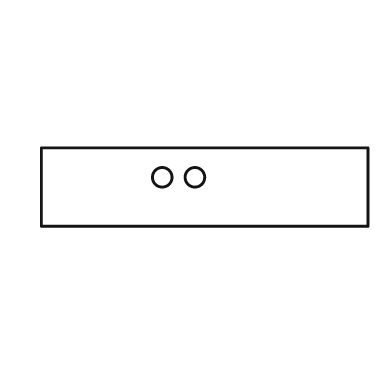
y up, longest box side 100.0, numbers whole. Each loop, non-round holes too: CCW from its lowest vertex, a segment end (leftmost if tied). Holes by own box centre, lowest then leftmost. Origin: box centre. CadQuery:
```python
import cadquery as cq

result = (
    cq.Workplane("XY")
    .moveTo(-50.0, -12.0)
    .lineTo(50.0, -12.0)
    .lineTo(50.0, 12.0)
    .lineTo(-50.0, 12.0)
    .close()
    .moveTo(-13.0, 3.0)
    .circle(3.0)
    .moveTo(-3.0, 3.0)
    .circle(3.0)
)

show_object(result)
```